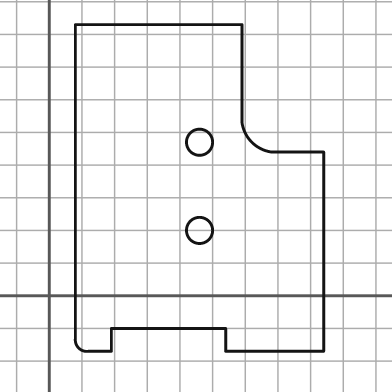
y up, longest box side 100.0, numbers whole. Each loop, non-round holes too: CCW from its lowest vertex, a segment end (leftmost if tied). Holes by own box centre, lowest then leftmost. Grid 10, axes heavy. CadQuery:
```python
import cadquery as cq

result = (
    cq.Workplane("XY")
    .moveTo(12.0, -17.0)
    .lineTo(19.0, -17.0)
    .lineTo(19.0, -10.0)
    .lineTo(54.0, -10.0)
    .lineTo(54.0, -17.0)
    .lineTo(84.0, -17.0)
    .lineTo(84.0, 44.0)
    .lineTo(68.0, 44.0)
    .threePointArc((62.0, 47.0), (59.0, 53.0))
    .lineTo(59.0, 83.0)
    .lineTo(8.0, 83.0)
    .lineTo(8.0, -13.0)
    .threePointArc((9.0, -16.0), (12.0, -17.0))
    .close()
    .moveTo(46.0, 20.0)
    .circle(4.0)
    .moveTo(46.0, 47.0)
    .circle(4.0)
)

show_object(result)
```